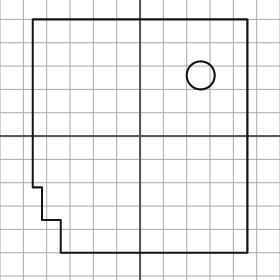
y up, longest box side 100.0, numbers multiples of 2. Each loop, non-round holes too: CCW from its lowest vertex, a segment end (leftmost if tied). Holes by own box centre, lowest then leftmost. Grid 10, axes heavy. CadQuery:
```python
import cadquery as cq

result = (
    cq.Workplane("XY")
    .moveTo(-34.0, -50.0)
    .lineTo(46.0, -50.0)
    .lineTo(46.0, 50.0)
    .lineTo(-46.0, 50.0)
    .lineTo(-46.0, -22.0)
    .lineTo(-42.0, -22.0)
    .lineTo(-42.0, -36.0)
    .lineTo(-34.0, -36.0)
    .close()
    .moveTo(26.0, 26.0)
    .circle(6.0)
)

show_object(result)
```